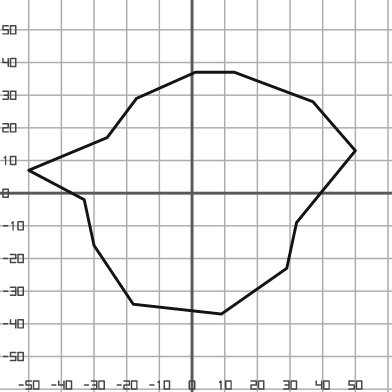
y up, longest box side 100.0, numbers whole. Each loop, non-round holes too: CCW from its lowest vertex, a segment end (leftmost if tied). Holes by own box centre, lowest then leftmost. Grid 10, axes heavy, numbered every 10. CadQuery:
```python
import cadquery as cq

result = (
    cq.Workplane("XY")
    .moveTo(9.0, -37.0)
    .lineTo(29.0, -23.0)
    .lineTo(32.0, -9.0)
    .lineTo(50.0, 13.0)
    .lineTo(37.0, 28.0)
    .lineTo(13.0, 37.0)
    .lineTo(1.0, 37.0)
    .lineTo(-17.0, 29.0)
    .lineTo(-26.0, 17.0)
    .lineTo(-50.0, 7.0)
    .lineTo(-33.0, -2.0)
    .lineTo(-30.0, -16.0)
    .lineTo(-18.0, -34.0)
    .close()
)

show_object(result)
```